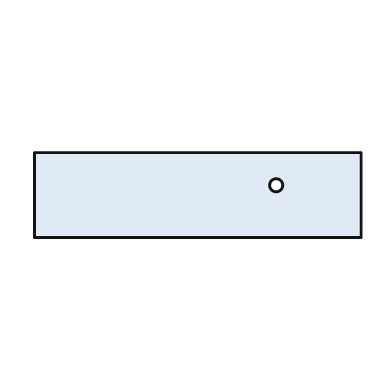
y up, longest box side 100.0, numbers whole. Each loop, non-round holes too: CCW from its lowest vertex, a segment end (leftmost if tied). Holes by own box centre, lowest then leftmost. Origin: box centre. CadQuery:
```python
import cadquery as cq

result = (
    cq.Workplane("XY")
    .moveTo(-50.0, -13.0)
    .lineTo(50.0, -13.0)
    .lineTo(50.0, 13.0)
    .lineTo(-50.0, 13.0)
    .close()
    .moveTo(24.0, 3.0)
    .circle(2.0)
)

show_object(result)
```